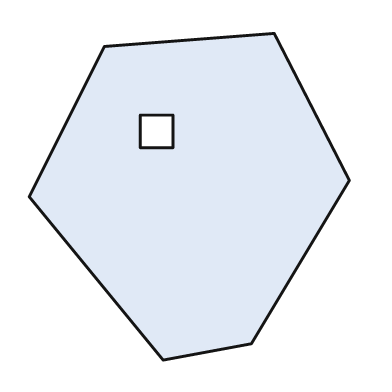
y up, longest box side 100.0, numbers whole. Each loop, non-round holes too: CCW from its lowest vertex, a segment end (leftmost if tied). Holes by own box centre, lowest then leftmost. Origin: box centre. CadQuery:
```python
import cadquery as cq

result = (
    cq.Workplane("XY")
    .moveTo(-8.0, -50.0)
    .lineTo(19.0, -45.0)
    .lineTo(49.0, 5.0)
    .lineTo(26.0, 50.0)
    .lineTo(-26.0, 46.0)
    .lineTo(-49.0, 0.0)
    .close()
    .moveTo(-15.0, 15.0)
    .lineTo(-5.0, 15.0)
    .lineTo(-5.0, 25.0)
    .lineTo(-15.0, 25.0)
    .close()
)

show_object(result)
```